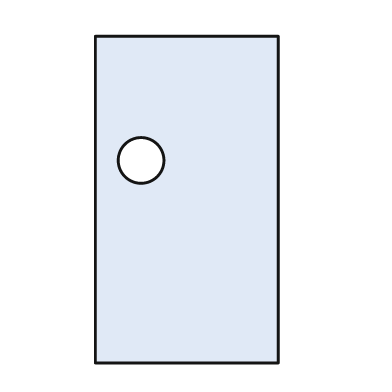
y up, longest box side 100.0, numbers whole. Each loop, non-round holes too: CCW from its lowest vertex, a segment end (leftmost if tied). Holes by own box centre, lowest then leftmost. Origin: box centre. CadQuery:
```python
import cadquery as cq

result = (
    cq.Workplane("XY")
    .moveTo(-28.0, -50.0)
    .lineTo(28.0, -50.0)
    .lineTo(28.0, 50.0)
    .lineTo(-28.0, 50.0)
    .close()
    .moveTo(-14.0, 12.0)
    .circle(7.0)
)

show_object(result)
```